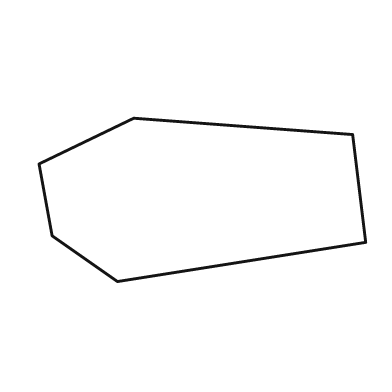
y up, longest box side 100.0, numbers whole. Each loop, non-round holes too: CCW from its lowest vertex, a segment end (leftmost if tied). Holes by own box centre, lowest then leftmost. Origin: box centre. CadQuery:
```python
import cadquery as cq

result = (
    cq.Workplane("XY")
    .moveTo(-26.0, -25.0)
    .lineTo(50.0, -13.0)
    .lineTo(46.0, 20.0)
    .lineTo(-21.0, 25.0)
    .lineTo(-50.0, 11.0)
    .lineTo(-46.0, -11.0)
    .close()
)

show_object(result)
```